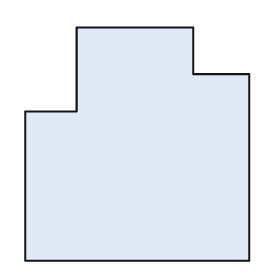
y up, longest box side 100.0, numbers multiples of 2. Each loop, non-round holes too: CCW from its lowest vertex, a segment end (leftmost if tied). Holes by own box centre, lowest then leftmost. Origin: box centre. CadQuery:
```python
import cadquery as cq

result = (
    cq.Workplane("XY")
    .moveTo(-48.0, -50.0)
    .lineTo(48.0, -50.0)
    .lineTo(48.0, 30.0)
    .lineTo(24.0, 30.0)
    .lineTo(24.0, 50.0)
    .lineTo(-26.0, 50.0)
    .lineTo(-26.0, 14.0)
    .lineTo(-48.0, 14.0)
    .close()
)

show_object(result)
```